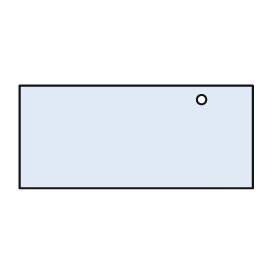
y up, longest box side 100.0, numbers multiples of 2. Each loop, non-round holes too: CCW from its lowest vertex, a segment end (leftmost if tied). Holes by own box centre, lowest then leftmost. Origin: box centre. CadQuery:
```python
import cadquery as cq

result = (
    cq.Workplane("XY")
    .moveTo(-50.0, -22.0)
    .lineTo(50.0, -22.0)
    .lineTo(50.0, 22.0)
    .lineTo(-50.0, 22.0)
    .close()
    .moveTo(28.0, 16.0)
    .circle(2.0)
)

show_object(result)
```